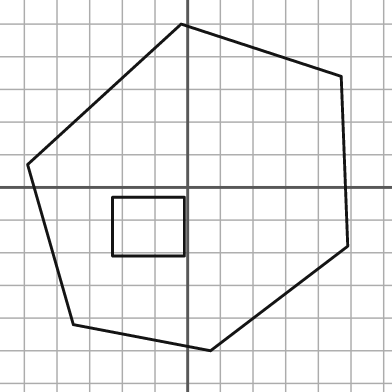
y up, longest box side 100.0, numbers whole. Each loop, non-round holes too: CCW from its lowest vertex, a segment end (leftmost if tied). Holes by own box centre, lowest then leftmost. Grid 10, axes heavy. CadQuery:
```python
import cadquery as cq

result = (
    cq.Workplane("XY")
    .moveTo(7.0, -50.0)
    .lineTo(49.0, -18.0)
    .lineTo(47.0, 34.0)
    .lineTo(-2.0, 50.0)
    .lineTo(-49.0, 7.0)
    .lineTo(-35.0, -42.0)
    .close()
    .moveTo(-23.0, -21.0)
    .lineTo(-1.0, -21.0)
    .lineTo(-1.0, -3.0)
    .lineTo(-23.0, -3.0)
    .close()
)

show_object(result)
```